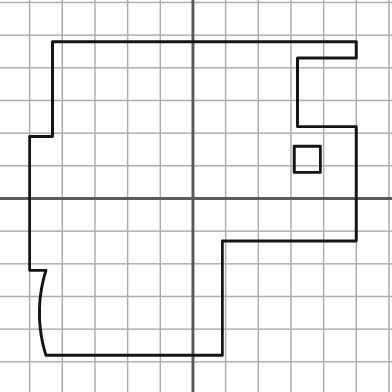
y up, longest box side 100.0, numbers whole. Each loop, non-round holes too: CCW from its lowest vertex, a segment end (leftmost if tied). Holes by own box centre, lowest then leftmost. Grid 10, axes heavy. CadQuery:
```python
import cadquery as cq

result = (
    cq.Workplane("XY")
    .moveTo(-45.0, -48.0)
    .lineTo(9.0, -48.0)
    .lineTo(9.0, -13.0)
    .lineTo(50.0, -13.0)
    .lineTo(50.0, 22.0)
    .lineTo(32.0, 22.0)
    .lineTo(32.0, 43.0)
    .lineTo(50.0, 43.0)
    .lineTo(50.0, 48.0)
    .lineTo(-43.0, 48.0)
    .lineTo(-43.0, 19.0)
    .lineTo(-50.0, 19.0)
    .lineTo(-50.0, -22.0)
    .lineTo(-45.0, -22.0)
    .threePointArc((-47.0, -35.0), (-45.0, -48.0))
    .close()
    .moveTo(31.0, 8.0)
    .lineTo(39.0, 8.0)
    .lineTo(39.0, 16.0)
    .lineTo(31.0, 16.0)
    .close()
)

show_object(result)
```